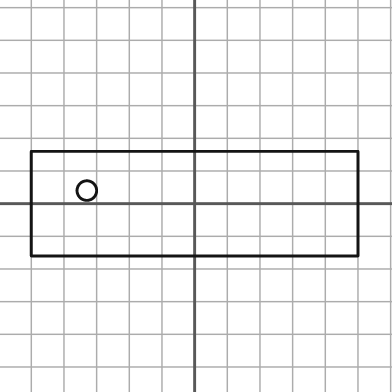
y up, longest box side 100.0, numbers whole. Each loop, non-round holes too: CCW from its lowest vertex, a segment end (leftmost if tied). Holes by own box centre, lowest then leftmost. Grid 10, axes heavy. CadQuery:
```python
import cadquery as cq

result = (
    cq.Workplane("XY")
    .moveTo(-50.0, -16.0)
    .lineTo(50.0, -16.0)
    .lineTo(50.0, 16.0)
    .lineTo(-50.0, 16.0)
    .close()
    .moveTo(-33.0, 4.0)
    .circle(3.0)
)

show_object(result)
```